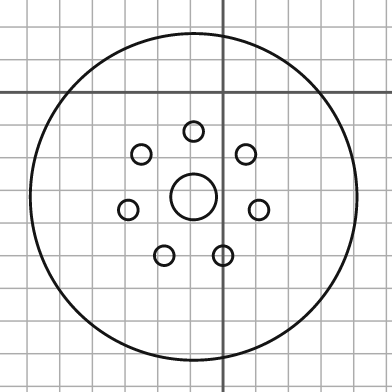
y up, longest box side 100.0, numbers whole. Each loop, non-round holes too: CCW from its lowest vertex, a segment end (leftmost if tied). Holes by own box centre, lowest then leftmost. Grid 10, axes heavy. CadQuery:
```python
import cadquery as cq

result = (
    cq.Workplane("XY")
    .moveTo(-9.0, -32.0)
    .circle(50.0)
    .moveTo(-18.0, -50.0)
    .circle(3.0)
    .moveTo(0.0, -50.0)
    .circle(3.0)
    .moveTo(-29.0, -36.0)
    .circle(3.0)
    .moveTo(11.0, -36.0)
    .circle(3.0)
    .moveTo(-9.0, -32.0)
    .circle(7.0)
    .moveTo(-25.0, -19.0)
    .circle(3.0)
    .moveTo(7.0, -19.0)
    .circle(3.0)
    .moveTo(-9.0, -12.0)
    .circle(3.0)
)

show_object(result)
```